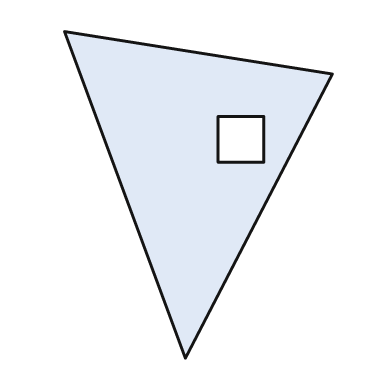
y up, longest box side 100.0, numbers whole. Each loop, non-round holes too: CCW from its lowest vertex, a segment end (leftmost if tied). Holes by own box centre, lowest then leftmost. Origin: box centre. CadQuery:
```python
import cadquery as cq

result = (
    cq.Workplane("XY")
    .moveTo(-4.0, -50.0)
    .lineTo(41.0, 37.0)
    .lineTo(-41.0, 50.0)
    .close()
    .moveTo(6.0, 10.0)
    .lineTo(20.0, 10.0)
    .lineTo(20.0, 24.0)
    .lineTo(6.0, 24.0)
    .close()
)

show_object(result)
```